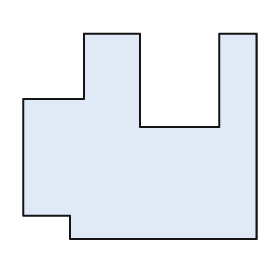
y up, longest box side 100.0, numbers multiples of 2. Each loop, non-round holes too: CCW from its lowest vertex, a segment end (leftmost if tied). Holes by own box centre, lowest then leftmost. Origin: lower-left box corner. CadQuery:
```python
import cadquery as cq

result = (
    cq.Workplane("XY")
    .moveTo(20.0, 0.0)
    .lineTo(100.0, 0.0)
    .lineTo(100.0, 88.0)
    .lineTo(84.0, 88.0)
    .lineTo(84.0, 48.0)
    .lineTo(50.0, 48.0)
    .lineTo(50.0, 88.0)
    .lineTo(26.0, 88.0)
    .lineTo(26.0, 60.0)
    .lineTo(0.0, 60.0)
    .lineTo(0.0, 10.0)
    .lineTo(20.0, 10.0)
    .close()
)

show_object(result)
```